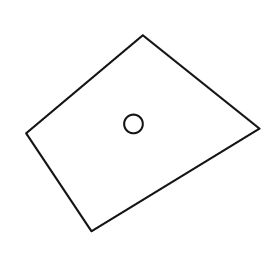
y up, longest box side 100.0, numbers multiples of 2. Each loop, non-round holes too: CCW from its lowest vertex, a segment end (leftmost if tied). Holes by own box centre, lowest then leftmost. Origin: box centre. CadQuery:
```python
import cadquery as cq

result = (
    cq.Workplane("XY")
    .moveTo(-22.0, -42.0)
    .lineTo(50.0, 2.0)
    .lineTo(0.0, 42.0)
    .lineTo(-50.0, 0.0)
    .close()
    .moveTo(-4.0, 4.0)
    .circle(4.0)
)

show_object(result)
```